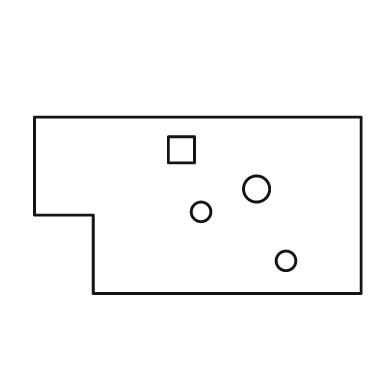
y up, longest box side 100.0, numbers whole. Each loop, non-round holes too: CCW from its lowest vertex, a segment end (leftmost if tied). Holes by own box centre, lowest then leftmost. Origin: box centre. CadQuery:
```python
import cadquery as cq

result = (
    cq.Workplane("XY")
    .moveTo(-32.0, -27.0)
    .lineTo(50.0, -27.0)
    .lineTo(50.0, 27.0)
    .lineTo(-50.0, 27.0)
    .lineTo(-50.0, -3.0)
    .lineTo(-32.0, -3.0)
    .close()
    .moveTo(27.0, -17.0)
    .circle(3.0)
    .moveTo(1.0, -2.0)
    .circle(3.0)
    .moveTo(18.0, 5.0)
    .circle(4.0)
    .moveTo(-9.0, 13.0)
    .lineTo(-1.0, 13.0)
    .lineTo(-1.0, 21.0)
    .lineTo(-9.0, 21.0)
    .close()
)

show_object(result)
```